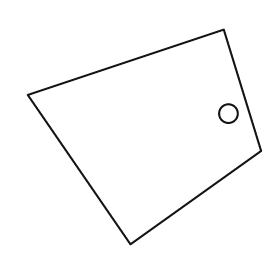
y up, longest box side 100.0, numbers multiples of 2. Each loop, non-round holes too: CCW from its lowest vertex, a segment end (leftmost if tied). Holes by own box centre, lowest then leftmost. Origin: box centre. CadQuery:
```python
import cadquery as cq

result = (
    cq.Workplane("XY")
    .moveTo(-6.0, -46.0)
    .lineTo(50.0, -6.0)
    .lineTo(34.0, 46.0)
    .lineTo(-50.0, 18.0)
    .close()
    .moveTo(36.0, 10.0)
    .circle(4.0)
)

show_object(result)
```